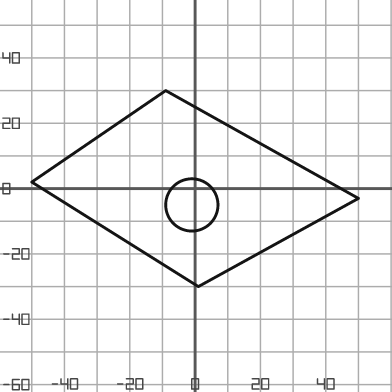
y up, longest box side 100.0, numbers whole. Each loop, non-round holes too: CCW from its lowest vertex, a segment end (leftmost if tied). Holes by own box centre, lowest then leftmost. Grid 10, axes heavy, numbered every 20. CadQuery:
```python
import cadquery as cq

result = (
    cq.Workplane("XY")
    .moveTo(1.0, -30.0)
    .lineTo(50.0, -3.0)
    .lineTo(-9.0, 30.0)
    .lineTo(-50.0, 2.0)
    .close()
    .moveTo(-1.0, -5.0)
    .circle(8.0)
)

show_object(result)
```